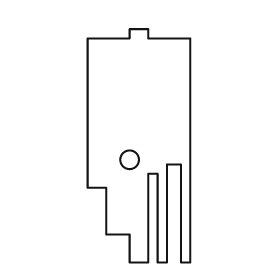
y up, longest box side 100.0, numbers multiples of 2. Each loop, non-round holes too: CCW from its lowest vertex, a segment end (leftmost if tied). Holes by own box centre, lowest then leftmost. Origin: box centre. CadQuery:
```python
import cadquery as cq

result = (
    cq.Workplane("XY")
    .moveTo(-4.0, -50.0)
    .lineTo(4.0, -50.0)
    .lineTo(4.0, -12.0)
    .lineTo(8.0, -12.0)
    .lineTo(8.0, -50.0)
    .lineTo(12.0, -50.0)
    .lineTo(12.0, -8.0)
    .lineTo(18.0, -8.0)
    .lineTo(18.0, -50.0)
    .lineTo(22.0, -50.0)
    .lineTo(22.0, 46.0)
    .lineTo(4.0, 46.0)
    .lineTo(4.0, 50.0)
    .lineTo(-4.0, 50.0)
    .lineTo(-4.0, 46.0)
    .lineTo(-22.0, 46.0)
    .lineTo(-22.0, -18.0)
    .lineTo(-14.0, -18.0)
    .lineTo(-14.0, -38.0)
    .lineTo(-4.0, -38.0)
    .close()
    .moveTo(-4.0, -6.0)
    .circle(4.0)
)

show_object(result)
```